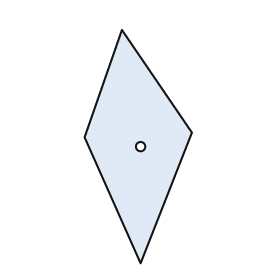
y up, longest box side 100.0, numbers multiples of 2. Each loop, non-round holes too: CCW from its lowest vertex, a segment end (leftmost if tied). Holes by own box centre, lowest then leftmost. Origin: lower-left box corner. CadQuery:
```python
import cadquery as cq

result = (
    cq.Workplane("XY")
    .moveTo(24.0, 0.0)
    .lineTo(46.0, 56.0)
    .lineTo(16.0, 100.0)
    .lineTo(0.0, 54.0)
    .close()
    .moveTo(24.0, 50.0)
    .circle(2.0)
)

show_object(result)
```